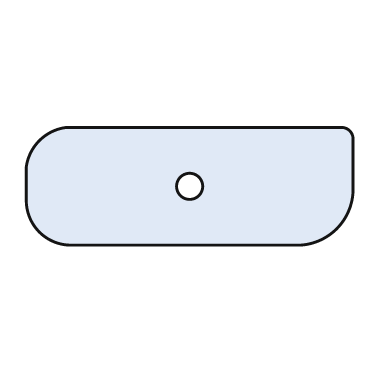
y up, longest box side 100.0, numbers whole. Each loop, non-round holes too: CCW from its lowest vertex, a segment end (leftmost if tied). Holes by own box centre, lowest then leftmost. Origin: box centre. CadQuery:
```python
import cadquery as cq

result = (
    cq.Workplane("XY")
    .moveTo(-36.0, -18.0)
    .lineTo(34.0, -18.0)
    .threePointArc((45.0, -13.0), (50.0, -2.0))
    .lineTo(50.0, 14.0)
    .threePointArc((49.0, 17.0), (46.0, 18.0))
    .lineTo(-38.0, 18.0)
    .threePointArc((-46.0, 14.0), (-50.0, 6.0))
    .lineTo(-50.0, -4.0)
    .threePointArc((-46.0, -14.0), (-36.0, -18.0))
    .close()
    .moveTo(0.0, 0.0)
    .circle(4.0)
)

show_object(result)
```